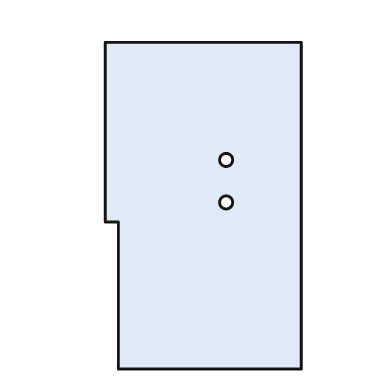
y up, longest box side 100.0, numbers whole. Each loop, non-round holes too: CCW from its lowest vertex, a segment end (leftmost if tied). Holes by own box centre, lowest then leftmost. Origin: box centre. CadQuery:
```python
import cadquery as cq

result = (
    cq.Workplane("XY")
    .moveTo(-26.0, -50.0)
    .lineTo(30.0, -50.0)
    .lineTo(30.0, 50.0)
    .lineTo(-30.0, 50.0)
    .lineTo(-30.0, -5.0)
    .lineTo(-26.0, -5.0)
    .close()
    .moveTo(7.0, 1.0)
    .circle(2.0)
    .moveTo(7.0, 14.0)
    .circle(2.0)
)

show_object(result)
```